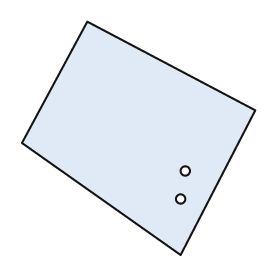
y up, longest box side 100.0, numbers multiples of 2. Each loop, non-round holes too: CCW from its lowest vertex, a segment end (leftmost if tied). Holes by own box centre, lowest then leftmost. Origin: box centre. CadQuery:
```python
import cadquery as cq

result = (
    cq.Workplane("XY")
    .moveTo(18.0, -50.0)
    .lineTo(50.0, 12.0)
    .lineTo(-22.0, 50.0)
    .lineTo(-50.0, -2.0)
    .close()
    .moveTo(18.0, -26.0)
    .circle(2.0)
    .moveTo(20.0, -14.0)
    .circle(2.0)
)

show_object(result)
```